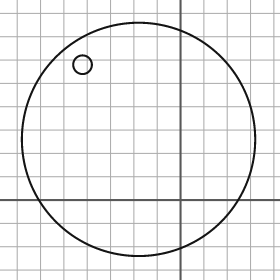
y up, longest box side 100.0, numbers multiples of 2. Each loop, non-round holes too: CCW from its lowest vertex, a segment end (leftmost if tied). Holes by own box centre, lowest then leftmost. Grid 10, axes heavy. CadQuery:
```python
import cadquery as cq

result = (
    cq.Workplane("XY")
    .moveTo(-18.0, 26.0)
    .circle(50.0)
    .moveTo(-42.0, 58.0)
    .circle(4.0)
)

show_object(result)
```